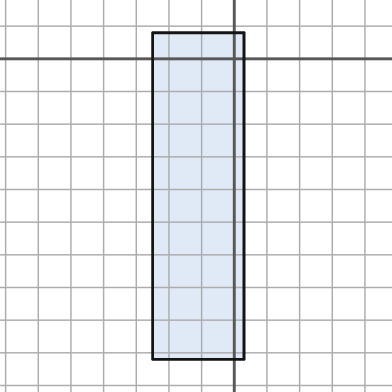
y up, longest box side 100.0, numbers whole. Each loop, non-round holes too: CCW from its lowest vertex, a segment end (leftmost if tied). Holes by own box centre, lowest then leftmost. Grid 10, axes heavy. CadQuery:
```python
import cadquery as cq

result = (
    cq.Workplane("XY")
    .moveTo(-25.0, -92.0)
    .lineTo(3.0, -92.0)
    .lineTo(3.0, 8.0)
    .lineTo(-25.0, 8.0)
    .close()
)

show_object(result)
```